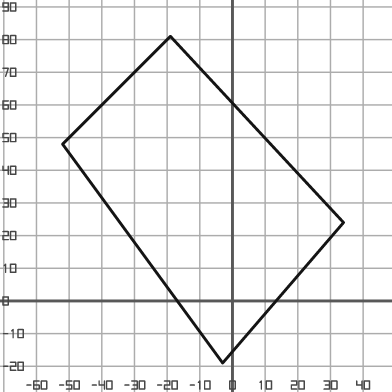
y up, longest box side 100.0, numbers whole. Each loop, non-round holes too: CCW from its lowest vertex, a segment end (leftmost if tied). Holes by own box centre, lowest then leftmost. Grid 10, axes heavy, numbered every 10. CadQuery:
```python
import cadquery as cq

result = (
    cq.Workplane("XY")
    .moveTo(-3.0, -19.0)
    .lineTo(34.0, 24.0)
    .lineTo(-19.0, 81.0)
    .lineTo(-52.0, 48.0)
    .close()
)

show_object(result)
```